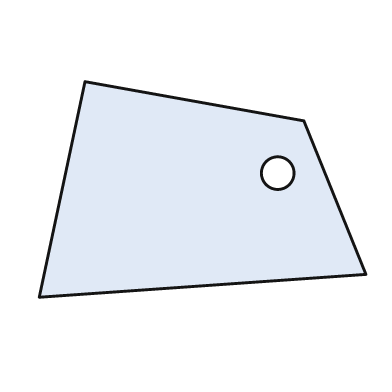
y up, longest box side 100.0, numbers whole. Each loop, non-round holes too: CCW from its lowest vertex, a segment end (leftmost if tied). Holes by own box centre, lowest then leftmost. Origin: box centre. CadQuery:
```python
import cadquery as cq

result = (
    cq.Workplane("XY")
    .moveTo(-50.0, -33.0)
    .lineTo(50.0, -26.0)
    .lineTo(31.0, 21.0)
    .lineTo(-36.0, 33.0)
    .close()
    .moveTo(23.0, 5.0)
    .circle(5.0)
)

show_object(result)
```